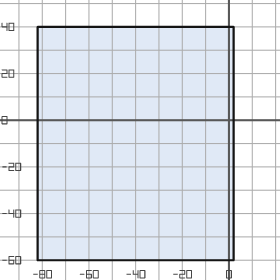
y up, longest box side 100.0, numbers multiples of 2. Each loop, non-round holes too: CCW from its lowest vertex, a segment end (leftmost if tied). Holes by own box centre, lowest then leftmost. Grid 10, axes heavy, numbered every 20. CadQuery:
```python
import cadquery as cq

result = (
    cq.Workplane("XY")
    .moveTo(-82.0, -60.0)
    .lineTo(2.0, -60.0)
    .lineTo(2.0, 40.0)
    .lineTo(-82.0, 40.0)
    .close()
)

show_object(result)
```